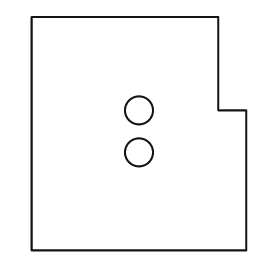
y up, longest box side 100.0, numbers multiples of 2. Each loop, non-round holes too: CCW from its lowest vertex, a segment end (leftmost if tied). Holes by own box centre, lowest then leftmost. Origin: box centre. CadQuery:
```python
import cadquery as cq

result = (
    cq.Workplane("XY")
    .moveTo(-46.0, -50.0)
    .lineTo(46.0, -50.0)
    .lineTo(46.0, 10.0)
    .lineTo(34.0, 10.0)
    .lineTo(34.0, 50.0)
    .lineTo(-46.0, 50.0)
    .close()
    .moveTo(0.0, -8.0)
    .circle(6.0)
    .moveTo(0.0, 10.0)
    .circle(6.0)
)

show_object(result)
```